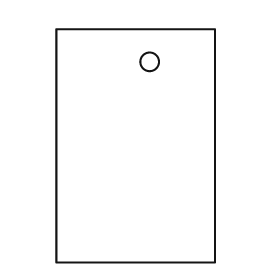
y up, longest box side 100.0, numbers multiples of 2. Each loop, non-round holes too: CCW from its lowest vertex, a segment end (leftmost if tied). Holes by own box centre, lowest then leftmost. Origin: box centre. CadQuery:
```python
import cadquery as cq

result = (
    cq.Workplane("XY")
    .moveTo(-34.0, -50.0)
    .lineTo(34.0, -50.0)
    .lineTo(34.0, 50.0)
    .lineTo(-34.0, 50.0)
    .close()
    .moveTo(6.0, 36.0)
    .circle(4.0)
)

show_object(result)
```